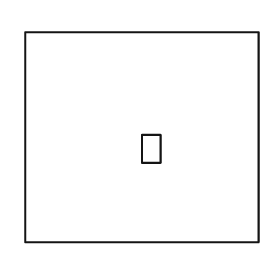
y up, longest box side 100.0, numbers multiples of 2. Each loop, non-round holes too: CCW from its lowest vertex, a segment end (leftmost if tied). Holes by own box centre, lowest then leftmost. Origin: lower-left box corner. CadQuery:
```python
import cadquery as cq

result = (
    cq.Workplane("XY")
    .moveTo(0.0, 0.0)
    .lineTo(100.0, 0.0)
    .lineTo(100.0, 90.0)
    .lineTo(0.0, 90.0)
    .close()
    .moveTo(50.0, 34.0)
    .lineTo(58.0, 34.0)
    .lineTo(58.0, 46.0)
    .lineTo(50.0, 46.0)
    .close()
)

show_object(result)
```